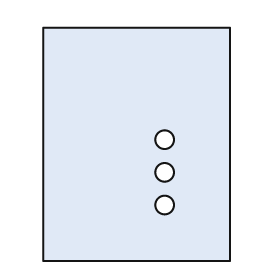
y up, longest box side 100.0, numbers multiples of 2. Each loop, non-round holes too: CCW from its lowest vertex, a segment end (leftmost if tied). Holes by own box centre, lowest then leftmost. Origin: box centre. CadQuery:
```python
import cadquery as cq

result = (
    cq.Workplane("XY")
    .moveTo(-40.0, -50.0)
    .lineTo(40.0, -50.0)
    .lineTo(40.0, 50.0)
    .lineTo(-40.0, 50.0)
    .close()
    .moveTo(12.0, -26.0)
    .circle(4.0)
    .moveTo(12.0, -12.0)
    .circle(4.0)
    .moveTo(12.0, 2.0)
    .circle(4.0)
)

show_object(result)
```